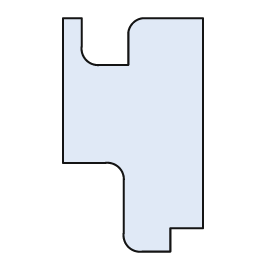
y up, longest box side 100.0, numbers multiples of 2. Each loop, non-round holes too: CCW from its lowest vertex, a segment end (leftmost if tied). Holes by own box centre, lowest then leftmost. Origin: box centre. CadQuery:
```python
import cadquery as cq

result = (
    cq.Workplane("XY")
    .moveTo(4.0, -50.0)
    .lineTo(16.0, -50.0)
    .lineTo(16.0, -40.0)
    .lineTo(30.0, -40.0)
    .lineTo(30.0, 50.0)
    .lineTo(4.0, 50.0)
    .threePointArc((0.0, 48.0), (-2.0, 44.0))
    .lineTo(-2.0, 30.0)
    .lineTo(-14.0, 30.0)
    .threePointArc((-20.0, 32.0), (-22.0, 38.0))
    .lineTo(-22.0, 50.0)
    .lineTo(-30.0, 50.0)
    .lineTo(-30.0, -12.0)
    .lineTo(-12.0, -12.0)
    .threePointArc((-6.0, -14.0), (-4.0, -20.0))
    .lineTo(-4.0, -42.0)
    .threePointArc((-2.0, -48.0), (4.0, -50.0))
    .close()
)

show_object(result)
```